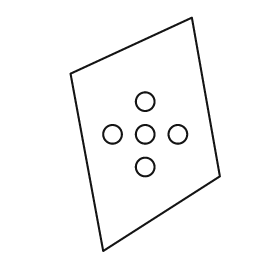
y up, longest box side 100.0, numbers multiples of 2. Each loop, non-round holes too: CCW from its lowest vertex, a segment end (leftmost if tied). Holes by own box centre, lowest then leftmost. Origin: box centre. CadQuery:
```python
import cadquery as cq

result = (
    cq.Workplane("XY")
    .moveTo(-18.0, -50.0)
    .lineTo(32.0, -18.0)
    .lineTo(20.0, 50.0)
    .lineTo(-32.0, 26.0)
    .close()
    .moveTo(0.0, -14.0)
    .circle(4.0)
    .moveTo(-14.0, 0.0)
    .circle(4.0)
    .moveTo(0.0, 0.0)
    .circle(4.0)
    .moveTo(14.0, 0.0)
    .circle(4.0)
    .moveTo(0.0, 14.0)
    .circle(4.0)
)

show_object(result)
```